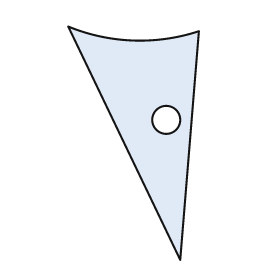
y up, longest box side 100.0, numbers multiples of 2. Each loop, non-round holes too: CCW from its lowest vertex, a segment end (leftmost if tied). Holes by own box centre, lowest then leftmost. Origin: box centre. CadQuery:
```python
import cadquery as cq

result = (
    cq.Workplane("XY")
    .moveTo(20.0, -50.0)
    .lineTo(28.0, 48.0)
    .threePointArc((0.0, 44.0), (-28.0, 50.0))
    .close()
    .moveTo(14.0, 10.0)
    .circle(6.0)
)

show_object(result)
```